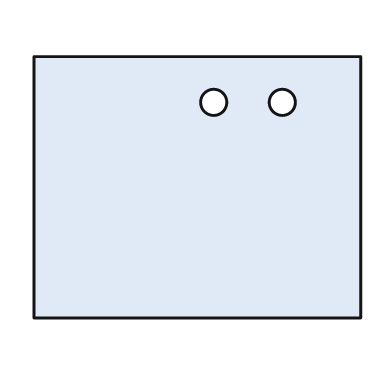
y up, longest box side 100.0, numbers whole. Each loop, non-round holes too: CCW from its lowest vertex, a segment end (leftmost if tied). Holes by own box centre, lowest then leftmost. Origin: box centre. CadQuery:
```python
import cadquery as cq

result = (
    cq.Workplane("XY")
    .moveTo(-50.0, -40.0)
    .lineTo(50.0, -40.0)
    .lineTo(50.0, 40.0)
    .lineTo(-50.0, 40.0)
    .close()
    .moveTo(5.0, 26.0)
    .circle(4.0)
    .moveTo(26.0, 26.0)
    .circle(4.0)
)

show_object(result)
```